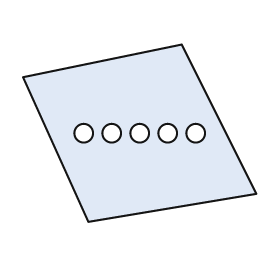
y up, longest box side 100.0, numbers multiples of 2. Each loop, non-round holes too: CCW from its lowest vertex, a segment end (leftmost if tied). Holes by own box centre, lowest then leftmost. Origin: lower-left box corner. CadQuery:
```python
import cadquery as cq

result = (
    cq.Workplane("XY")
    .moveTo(28.0, 0.0)
    .lineTo(100.0, 12.0)
    .lineTo(68.0, 76.0)
    .lineTo(0.0, 62.0)
    .close()
    .moveTo(26.0, 38.0)
    .circle(4.0)
    .moveTo(38.0, 38.0)
    .circle(4.0)
    .moveTo(50.0, 38.0)
    .circle(4.0)
    .moveTo(62.0, 38.0)
    .circle(4.0)
    .moveTo(74.0, 38.0)
    .circle(4.0)
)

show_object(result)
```